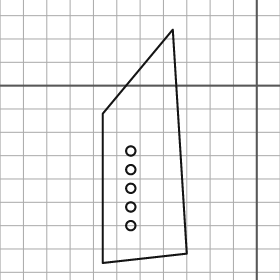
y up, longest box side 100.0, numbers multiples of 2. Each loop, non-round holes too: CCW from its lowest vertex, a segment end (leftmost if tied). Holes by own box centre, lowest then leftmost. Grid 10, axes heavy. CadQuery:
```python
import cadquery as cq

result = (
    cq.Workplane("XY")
    .moveTo(-66.0, -76.0)
    .lineTo(-30.0, -72.0)
    .lineTo(-36.0, 24.0)
    .lineTo(-66.0, -12.0)
    .close()
    .moveTo(-54.0, -60.0)
    .circle(2.0)
    .moveTo(-54.0, -52.0)
    .circle(2.0)
    .moveTo(-54.0, -44.0)
    .circle(2.0)
    .moveTo(-54.0, -36.0)
    .circle(2.0)
    .moveTo(-54.0, -28.0)
    .circle(2.0)
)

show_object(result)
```